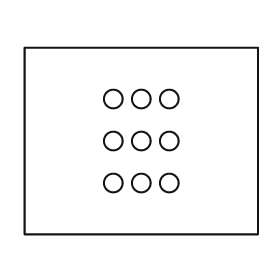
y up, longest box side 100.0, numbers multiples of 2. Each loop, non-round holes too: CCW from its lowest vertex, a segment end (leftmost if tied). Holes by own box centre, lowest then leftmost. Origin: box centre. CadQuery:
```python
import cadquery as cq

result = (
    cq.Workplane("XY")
    .moveTo(-50.0, -40.0)
    .lineTo(50.0, -40.0)
    .lineTo(50.0, 40.0)
    .lineTo(-50.0, 40.0)
    .close()
    .moveTo(-12.0, -18.0)
    .circle(4.0)
    .moveTo(0.0, -18.0)
    .circle(4.0)
    .moveTo(12.0, -18.0)
    .circle(4.0)
    .moveTo(-12.0, 0.0)
    .circle(4.0)
    .moveTo(0.0, 0.0)
    .circle(4.0)
    .moveTo(12.0, 0.0)
    .circle(4.0)
    .moveTo(-12.0, 18.0)
    .circle(4.0)
    .moveTo(0.0, 18.0)
    .circle(4.0)
    .moveTo(12.0, 18.0)
    .circle(4.0)
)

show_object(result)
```